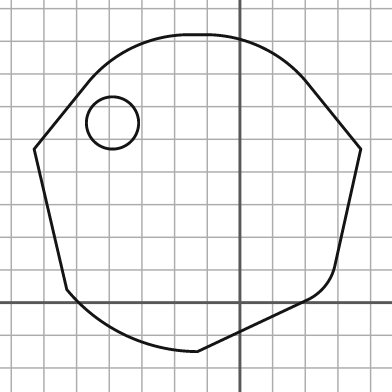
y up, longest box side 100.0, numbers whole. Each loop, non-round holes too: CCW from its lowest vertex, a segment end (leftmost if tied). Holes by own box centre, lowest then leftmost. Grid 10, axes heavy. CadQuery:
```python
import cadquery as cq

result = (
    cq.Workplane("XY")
    .moveTo(-13.0, -15.0)
    .lineTo(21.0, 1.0)
    .threePointArc((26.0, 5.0), (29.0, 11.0))
    .lineTo(37.0, 47.0)
    .lineTo(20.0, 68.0)
    .threePointArc((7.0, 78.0), (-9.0, 82.0))
    .lineTo(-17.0, 82.0)
    .threePointArc((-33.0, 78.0), (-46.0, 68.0))
    .lineTo(-63.0, 47.0)
    .lineTo(-53.0, 4.0)
    .threePointArc((-35.0, -10.0), (-13.0, -15.0))
    .close()
    .moveTo(-39.0, 55.0)
    .circle(8.0)
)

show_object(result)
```